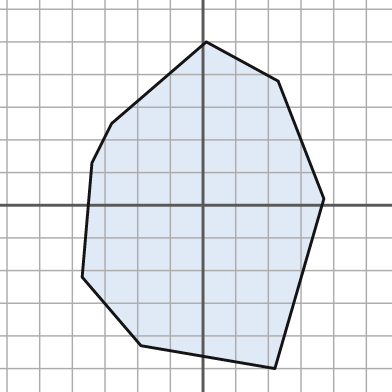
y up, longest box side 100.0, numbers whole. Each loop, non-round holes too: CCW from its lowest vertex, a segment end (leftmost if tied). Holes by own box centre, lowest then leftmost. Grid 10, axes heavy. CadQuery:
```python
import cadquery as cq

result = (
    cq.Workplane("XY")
    .moveTo(22.0, -50.0)
    .lineTo(37.0, 2.0)
    .lineTo(23.0, 38.0)
    .lineTo(1.0, 50.0)
    .lineTo(-28.0, 25.0)
    .lineTo(-34.0, 13.0)
    .lineTo(-37.0, -22.0)
    .lineTo(-19.0, -43.0)
    .close()
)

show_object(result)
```